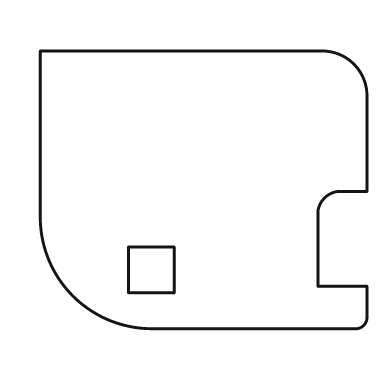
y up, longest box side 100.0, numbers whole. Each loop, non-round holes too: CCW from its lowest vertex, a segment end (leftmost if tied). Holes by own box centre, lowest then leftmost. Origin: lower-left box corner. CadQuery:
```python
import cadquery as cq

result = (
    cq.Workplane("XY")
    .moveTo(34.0, 0.0)
    .lineTo(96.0, 0.0)
    .threePointArc((99.0, 1.0), (100.0, 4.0))
    .lineTo(100.0, 13.0)
    .lineTo(85.0, 13.0)
    .lineTo(85.0, 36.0)
    .threePointArc((87.0, 40.0), (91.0, 42.0))
    .lineTo(100.0, 42.0)
    .lineTo(100.0, 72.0)
    .threePointArc((96.0, 81.0), (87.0, 85.0))
    .lineTo(0.0, 85.0)
    .lineTo(0.0, 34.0)
    .threePointArc((10.0, 10.0), (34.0, 0.0))
    .close()
    .moveTo(27.0, 11.0)
    .lineTo(41.0, 11.0)
    .lineTo(41.0, 25.0)
    .lineTo(27.0, 25.0)
    .close()
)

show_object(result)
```